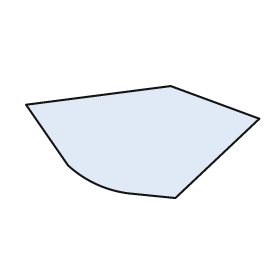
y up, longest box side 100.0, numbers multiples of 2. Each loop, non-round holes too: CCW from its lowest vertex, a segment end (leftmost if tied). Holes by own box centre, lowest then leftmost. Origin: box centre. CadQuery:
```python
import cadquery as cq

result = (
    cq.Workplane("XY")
    .moveTo(14.0, -24.0)
    .lineTo(50.0, 10.0)
    .lineTo(12.0, 24.0)
    .lineTo(-50.0, 16.0)
    .lineTo(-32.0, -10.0)
    .threePointArc((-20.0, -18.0), (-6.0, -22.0))
    .close()
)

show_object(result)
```